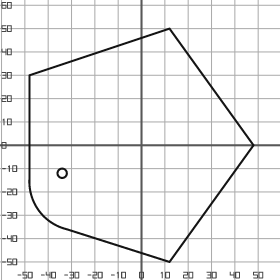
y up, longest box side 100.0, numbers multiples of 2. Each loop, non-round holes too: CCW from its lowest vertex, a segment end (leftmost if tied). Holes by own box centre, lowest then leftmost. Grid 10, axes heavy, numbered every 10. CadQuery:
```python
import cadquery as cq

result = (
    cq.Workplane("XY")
    .moveTo(12.0, -50.0)
    .lineTo(48.0, 0.0)
    .lineTo(12.0, 50.0)
    .lineTo(-48.0, 30.0)
    .lineTo(-48.0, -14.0)
    .threePointArc((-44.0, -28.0), (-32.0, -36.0))
    .close()
    .moveTo(-34.0, -12.0)
    .circle(2.0)
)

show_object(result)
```